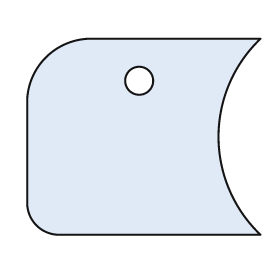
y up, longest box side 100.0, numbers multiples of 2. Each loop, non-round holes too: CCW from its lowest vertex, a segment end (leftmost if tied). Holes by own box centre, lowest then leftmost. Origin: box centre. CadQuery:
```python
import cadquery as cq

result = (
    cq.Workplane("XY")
    .moveTo(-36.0, -42.0)
    .lineTo(50.0, -42.0)
    .threePointArc((32.0, 0.0), (50.0, 42.0))
    .lineTo(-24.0, 42.0)
    .threePointArc((-42.0, 34.0), (-50.0, 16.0))
    .lineTo(-50.0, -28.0)
    .threePointArc((-46.0, -38.0), (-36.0, -42.0))
    .close()
    .moveTo(-2.0, 24.0)
    .circle(6.0)
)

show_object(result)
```